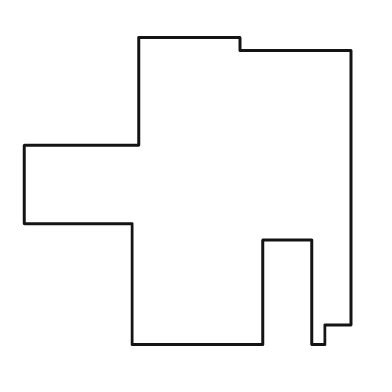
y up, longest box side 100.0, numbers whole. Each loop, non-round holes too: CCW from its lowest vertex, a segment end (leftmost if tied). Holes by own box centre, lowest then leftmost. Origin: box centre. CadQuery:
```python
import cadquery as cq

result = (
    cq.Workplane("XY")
    .moveTo(-17.0, -47.0)
    .lineTo(23.0, -47.0)
    .lineTo(23.0, -15.0)
    .lineTo(38.0, -15.0)
    .lineTo(38.0, -47.0)
    .lineTo(42.0, -47.0)
    .lineTo(42.0, -41.0)
    .lineTo(50.0, -41.0)
    .lineTo(50.0, 43.0)
    .lineTo(16.0, 43.0)
    .lineTo(16.0, 47.0)
    .lineTo(-15.0, 47.0)
    .lineTo(-15.0, 14.0)
    .lineTo(-50.0, 14.0)
    .lineTo(-50.0, -10.0)
    .lineTo(-17.0, -10.0)
    .close()
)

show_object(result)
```